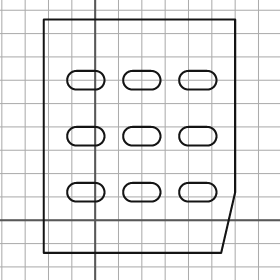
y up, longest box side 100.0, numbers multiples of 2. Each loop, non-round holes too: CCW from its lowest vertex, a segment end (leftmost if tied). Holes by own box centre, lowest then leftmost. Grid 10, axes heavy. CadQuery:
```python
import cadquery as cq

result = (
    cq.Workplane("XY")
    .moveTo(-22.0, -14.0)
    .lineTo(54.0, -14.0)
    .lineTo(60.0, 12.0)
    .lineTo(60.0, 86.0)
    .lineTo(-22.0, 86.0)
    .close()
    .moveTo(-8.0, 8.0)
    .lineTo(0.0, 8.0)
    .threePointArc((4.0, 12.0), (0.0, 16.0))
    .lineTo(-8.0, 16.0)
    .threePointArc((-12.0, 12.0), (-8.0, 8.0))
    .close()
    .moveTo(16.0, 8.0)
    .lineTo(24.0, 8.0)
    .threePointArc((28.0, 12.0), (24.0, 16.0))
    .lineTo(16.0, 16.0)
    .threePointArc((12.0, 12.0), (16.0, 8.0))
    .close()
    .moveTo(40.0, 8.0)
    .lineTo(48.0, 8.0)
    .threePointArc((52.0, 12.0), (48.0, 16.0))
    .lineTo(40.0, 16.0)
    .threePointArc((36.0, 12.0), (40.0, 8.0))
    .close()
    .moveTo(-8.0, 32.0)
    .lineTo(0.0, 32.0)
    .threePointArc((4.0, 36.0), (0.0, 40.0))
    .lineTo(-8.0, 40.0)
    .threePointArc((-12.0, 36.0), (-8.0, 32.0))
    .close()
    .moveTo(16.0, 32.0)
    .lineTo(24.0, 32.0)
    .threePointArc((28.0, 36.0), (24.0, 40.0))
    .lineTo(16.0, 40.0)
    .threePointArc((12.0, 36.0), (16.0, 32.0))
    .close()
    .moveTo(40.0, 32.0)
    .lineTo(48.0, 32.0)
    .threePointArc((52.0, 36.0), (48.0, 40.0))
    .lineTo(40.0, 40.0)
    .threePointArc((36.0, 36.0), (40.0, 32.0))
    .close()
    .moveTo(-8.0, 56.0)
    .lineTo(0.0, 56.0)
    .threePointArc((4.0, 60.0), (0.0, 64.0))
    .lineTo(-8.0, 64.0)
    .threePointArc((-12.0, 60.0), (-8.0, 56.0))
    .close()
    .moveTo(16.0, 56.0)
    .lineTo(24.0, 56.0)
    .threePointArc((28.0, 60.0), (24.0, 64.0))
    .lineTo(16.0, 64.0)
    .threePointArc((12.0, 60.0), (16.0, 56.0))
    .close()
    .moveTo(40.0, 56.0)
    .lineTo(48.0, 56.0)
    .threePointArc((52.0, 60.0), (48.0, 64.0))
    .lineTo(40.0, 64.0)
    .threePointArc((36.0, 60.0), (40.0, 56.0))
    .close()
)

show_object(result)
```